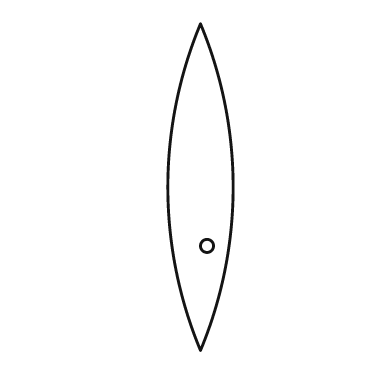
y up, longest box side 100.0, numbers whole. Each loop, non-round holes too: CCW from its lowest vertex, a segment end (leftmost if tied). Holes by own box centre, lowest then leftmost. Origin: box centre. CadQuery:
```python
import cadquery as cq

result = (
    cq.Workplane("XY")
    .moveTo(0.0, -50.0)
    .threePointArc((10.0, 0.0), (0.0, 50.0))
    .threePointArc((-10.0, 0.0), (0.0, -50.0))
    .close()
    .moveTo(2.0, -18.0)
    .circle(2.0)
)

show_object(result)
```